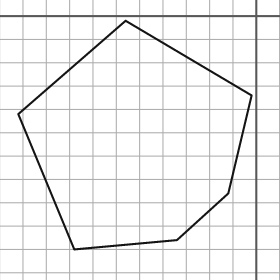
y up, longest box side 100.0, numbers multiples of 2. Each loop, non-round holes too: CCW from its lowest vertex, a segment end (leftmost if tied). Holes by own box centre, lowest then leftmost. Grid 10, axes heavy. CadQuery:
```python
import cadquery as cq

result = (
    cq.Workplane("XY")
    .moveTo(-78.0, -100.0)
    .lineTo(-34.0, -96.0)
    .lineTo(-12.0, -76.0)
    .lineTo(-2.0, -34.0)
    .lineTo(-56.0, -2.0)
    .lineTo(-102.0, -42.0)
    .close()
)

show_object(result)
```